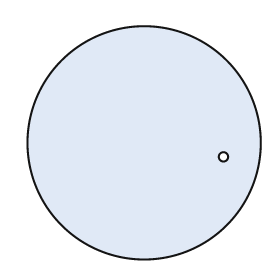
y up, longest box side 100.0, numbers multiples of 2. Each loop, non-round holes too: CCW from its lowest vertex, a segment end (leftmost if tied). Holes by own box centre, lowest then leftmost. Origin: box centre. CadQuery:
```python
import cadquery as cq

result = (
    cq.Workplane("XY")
    .moveTo(0.0, 0.0)
    .circle(50.0)
    .moveTo(34.0, -6.0)
    .circle(2.0)
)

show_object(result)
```